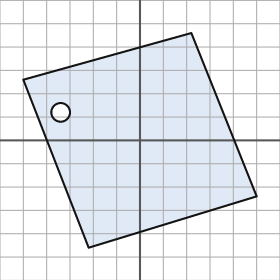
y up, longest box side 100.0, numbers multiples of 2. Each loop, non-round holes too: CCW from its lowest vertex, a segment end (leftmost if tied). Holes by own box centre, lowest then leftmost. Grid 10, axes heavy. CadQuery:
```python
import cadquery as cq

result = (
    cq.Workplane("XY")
    .moveTo(-22.0, -46.0)
    .lineTo(50.0, -24.0)
    .lineTo(22.0, 46.0)
    .lineTo(-50.0, 26.0)
    .close()
    .moveTo(-34.0, 12.0)
    .circle(4.0)
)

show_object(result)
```